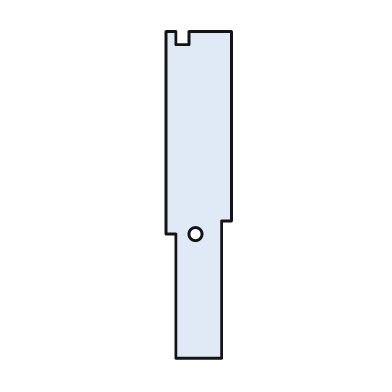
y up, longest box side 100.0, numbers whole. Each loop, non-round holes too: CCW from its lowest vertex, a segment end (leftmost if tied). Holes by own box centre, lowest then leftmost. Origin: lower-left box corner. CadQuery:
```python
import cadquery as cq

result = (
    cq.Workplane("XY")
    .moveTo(3.0, 0.0)
    .lineTo(17.0, 0.0)
    .lineTo(17.0, 42.0)
    .lineTo(20.0, 42.0)
    .lineTo(20.0, 100.0)
    .lineTo(7.0, 100.0)
    .lineTo(7.0, 96.0)
    .lineTo(3.0, 96.0)
    .lineTo(3.0, 100.0)
    .lineTo(0.0, 100.0)
    .lineTo(0.0, 38.0)
    .lineTo(3.0, 38.0)
    .close()
    .moveTo(9.0, 38.0)
    .circle(2.0)
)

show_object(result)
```